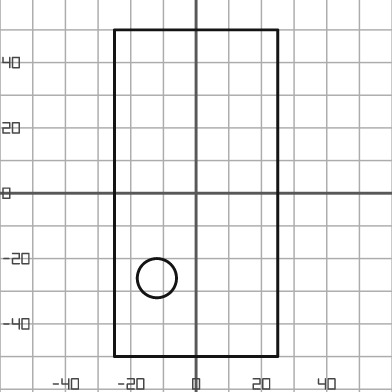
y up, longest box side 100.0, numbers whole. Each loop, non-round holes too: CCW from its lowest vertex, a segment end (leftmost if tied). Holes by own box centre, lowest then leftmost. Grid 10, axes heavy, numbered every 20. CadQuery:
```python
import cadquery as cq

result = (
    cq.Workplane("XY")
    .moveTo(-25.0, -50.0)
    .lineTo(25.0, -50.0)
    .lineTo(25.0, 50.0)
    .lineTo(-25.0, 50.0)
    .close()
    .moveTo(-12.0, -26.0)
    .circle(6.0)
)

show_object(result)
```